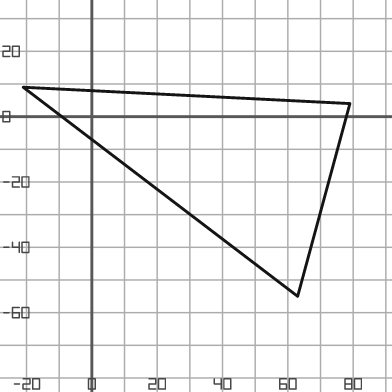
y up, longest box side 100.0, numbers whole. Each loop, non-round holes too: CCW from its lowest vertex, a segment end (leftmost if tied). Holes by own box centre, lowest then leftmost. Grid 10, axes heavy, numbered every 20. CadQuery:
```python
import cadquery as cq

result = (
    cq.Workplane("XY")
    .moveTo(63.0, -55.0)
    .lineTo(79.0, 4.0)
    .lineTo(-21.0, 9.0)
    .close()
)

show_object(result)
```